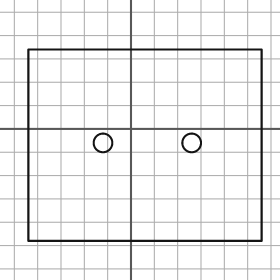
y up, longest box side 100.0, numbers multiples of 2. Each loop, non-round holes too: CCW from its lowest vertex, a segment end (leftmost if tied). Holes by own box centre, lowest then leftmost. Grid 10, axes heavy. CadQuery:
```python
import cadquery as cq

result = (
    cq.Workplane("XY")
    .moveTo(-44.0, -48.0)
    .lineTo(56.0, -48.0)
    .lineTo(56.0, 34.0)
    .lineTo(-44.0, 34.0)
    .close()
    .moveTo(-12.0, -6.0)
    .circle(4.0)
    .moveTo(26.0, -6.0)
    .circle(4.0)
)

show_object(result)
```